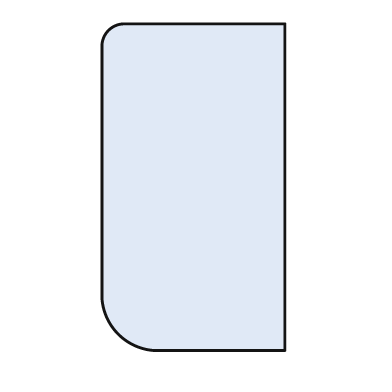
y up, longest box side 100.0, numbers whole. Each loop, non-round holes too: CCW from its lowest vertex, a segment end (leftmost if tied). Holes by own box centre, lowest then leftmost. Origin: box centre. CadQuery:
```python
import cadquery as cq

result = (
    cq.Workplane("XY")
    .moveTo(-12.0, -50.0)
    .lineTo(28.0, -50.0)
    .lineTo(28.0, 50.0)
    .lineTo(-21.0, 50.0)
    .threePointArc((-26.0, 48.0), (-28.0, 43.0))
    .lineTo(-28.0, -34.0)
    .threePointArc((-23.0, -45.0), (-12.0, -50.0))
    .close()
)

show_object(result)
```